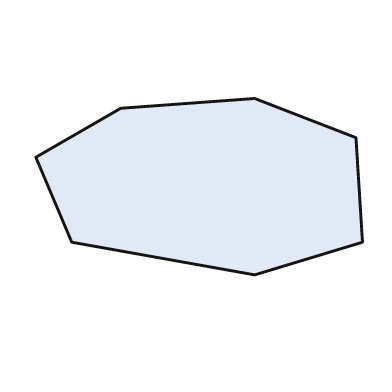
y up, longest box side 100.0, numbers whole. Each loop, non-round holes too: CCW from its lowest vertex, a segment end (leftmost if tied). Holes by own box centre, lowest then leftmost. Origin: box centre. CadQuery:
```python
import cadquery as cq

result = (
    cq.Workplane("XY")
    .moveTo(17.0, -27.0)
    .lineTo(50.0, -17.0)
    .lineTo(48.0, 15.0)
    .lineTo(17.0, 27.0)
    .lineTo(-24.0, 24.0)
    .lineTo(-50.0, 9.0)
    .lineTo(-39.0, -17.0)
    .close()
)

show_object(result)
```